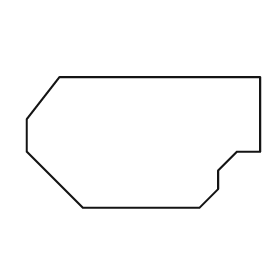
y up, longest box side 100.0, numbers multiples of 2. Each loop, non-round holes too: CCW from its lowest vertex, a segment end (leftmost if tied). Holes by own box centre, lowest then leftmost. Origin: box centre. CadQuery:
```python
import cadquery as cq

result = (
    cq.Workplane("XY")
    .moveTo(-26.0, -28.0)
    .lineTo(24.0, -28.0)
    .lineTo(32.0, -20.0)
    .lineTo(32.0, -12.0)
    .lineTo(40.0, -4.0)
    .lineTo(50.0, -4.0)
    .lineTo(50.0, 28.0)
    .lineTo(-36.0, 28.0)
    .lineTo(-50.0, 10.0)
    .lineTo(-50.0, -4.0)
    .close()
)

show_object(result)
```